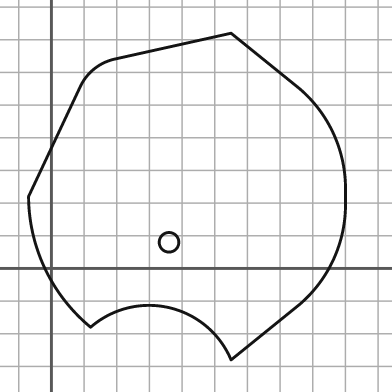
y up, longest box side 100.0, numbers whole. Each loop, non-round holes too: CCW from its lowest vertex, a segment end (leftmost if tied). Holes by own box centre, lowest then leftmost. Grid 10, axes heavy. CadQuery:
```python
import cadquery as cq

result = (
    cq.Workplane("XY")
    .moveTo(55.0, -28.0)
    .lineTo(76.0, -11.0)
    .threePointArc((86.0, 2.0), (90.0, 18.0))
    .lineTo(90.0, 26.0)
    .threePointArc((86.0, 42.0), (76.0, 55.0))
    .lineTo(55.0, 72.0)
    .lineTo(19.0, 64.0)
    .threePointArc((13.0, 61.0), (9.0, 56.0))
    .lineTo(-7.0, 22.0)
    .threePointArc((-2.0, 0.0), (12.0, -18.0))
    .threePointArc((36.0, -12.0), (55.0, -28.0))
    .close()
    .moveTo(36.0, 8.0)
    .circle(3.0)
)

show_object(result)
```